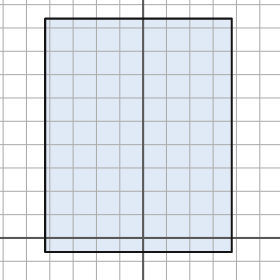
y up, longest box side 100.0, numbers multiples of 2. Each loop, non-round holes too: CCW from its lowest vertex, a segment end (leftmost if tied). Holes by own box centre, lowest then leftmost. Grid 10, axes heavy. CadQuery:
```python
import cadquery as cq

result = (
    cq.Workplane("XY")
    .moveTo(-42.0, -6.0)
    .lineTo(38.0, -6.0)
    .lineTo(38.0, 94.0)
    .lineTo(-42.0, 94.0)
    .close()
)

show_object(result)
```